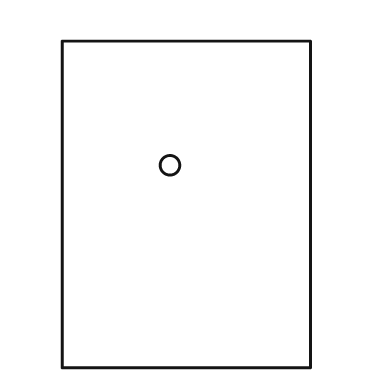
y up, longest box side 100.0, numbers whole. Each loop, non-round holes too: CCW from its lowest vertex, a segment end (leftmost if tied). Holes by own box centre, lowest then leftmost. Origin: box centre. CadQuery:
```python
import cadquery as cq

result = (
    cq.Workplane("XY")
    .moveTo(-38.0, -50.0)
    .lineTo(38.0, -50.0)
    .lineTo(38.0, 50.0)
    .lineTo(-38.0, 50.0)
    .close()
    .moveTo(-5.0, 12.0)
    .circle(3.0)
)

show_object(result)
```